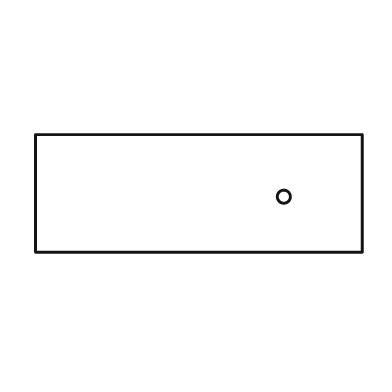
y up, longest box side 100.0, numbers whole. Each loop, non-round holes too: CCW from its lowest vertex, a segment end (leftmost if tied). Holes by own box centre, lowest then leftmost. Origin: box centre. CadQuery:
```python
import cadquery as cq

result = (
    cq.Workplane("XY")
    .moveTo(-50.0, -18.0)
    .lineTo(50.0, -18.0)
    .lineTo(50.0, 18.0)
    .lineTo(-50.0, 18.0)
    .close()
    .moveTo(26.0, -1.0)
    .circle(2.0)
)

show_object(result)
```